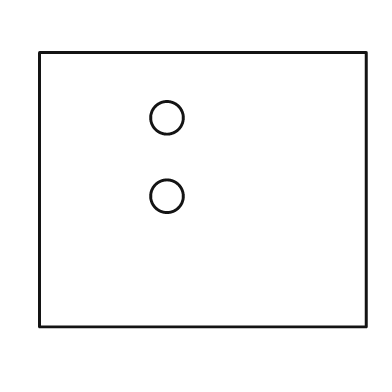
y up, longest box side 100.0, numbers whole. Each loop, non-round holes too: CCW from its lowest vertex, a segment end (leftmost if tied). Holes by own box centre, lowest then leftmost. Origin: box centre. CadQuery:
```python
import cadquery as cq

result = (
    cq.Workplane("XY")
    .moveTo(-50.0, -42.0)
    .lineTo(50.0, -42.0)
    .lineTo(50.0, 42.0)
    .lineTo(-50.0, 42.0)
    .close()
    .moveTo(-11.0, -2.0)
    .circle(5.0)
    .moveTo(-11.0, 22.0)
    .circle(5.0)
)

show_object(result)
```